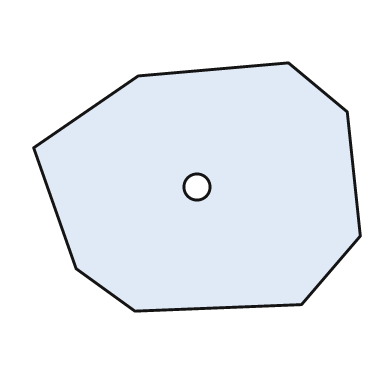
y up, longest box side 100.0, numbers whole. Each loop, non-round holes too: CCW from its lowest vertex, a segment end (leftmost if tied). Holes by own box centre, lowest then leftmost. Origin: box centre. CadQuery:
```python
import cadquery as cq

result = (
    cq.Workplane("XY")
    .moveTo(-19.0, -38.0)
    .lineTo(32.0, -36.0)
    .lineTo(50.0, -15.0)
    .lineTo(46.0, 23.0)
    .lineTo(28.0, 38.0)
    .lineTo(-18.0, 34.0)
    .lineTo(-50.0, 12.0)
    .lineTo(-37.0, -25.0)
    .close()
    .moveTo(0.0, 0.0)
    .circle(4.0)
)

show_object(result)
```